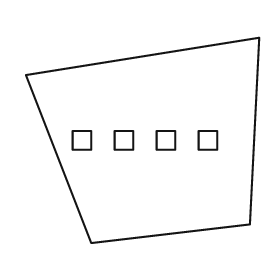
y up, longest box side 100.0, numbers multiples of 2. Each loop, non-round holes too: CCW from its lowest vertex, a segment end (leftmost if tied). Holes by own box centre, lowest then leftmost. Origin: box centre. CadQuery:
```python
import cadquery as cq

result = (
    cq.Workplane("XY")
    .moveTo(-22.0, -44.0)
    .lineTo(46.0, -36.0)
    .lineTo(50.0, 44.0)
    .lineTo(-50.0, 28.0)
    .close()
    .moveTo(-30.0, -4.0)
    .lineTo(-22.0, -4.0)
    .lineTo(-22.0, 4.0)
    .lineTo(-30.0, 4.0)
    .close()
    .moveTo(-12.0, -4.0)
    .lineTo(-4.0, -4.0)
    .lineTo(-4.0, 4.0)
    .lineTo(-12.0, 4.0)
    .close()
    .moveTo(6.0, -4.0)
    .lineTo(14.0, -4.0)
    .lineTo(14.0, 4.0)
    .lineTo(6.0, 4.0)
    .close()
    .moveTo(24.0, -4.0)
    .lineTo(32.0, -4.0)
    .lineTo(32.0, 4.0)
    .lineTo(24.0, 4.0)
    .close()
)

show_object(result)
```